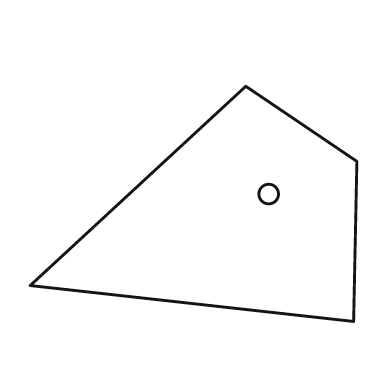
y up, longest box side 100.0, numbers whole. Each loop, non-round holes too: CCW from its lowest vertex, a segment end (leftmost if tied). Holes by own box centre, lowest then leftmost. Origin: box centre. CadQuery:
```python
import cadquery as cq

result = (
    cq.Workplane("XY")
    .moveTo(49.0, -36.0)
    .lineTo(50.0, 13.0)
    .lineTo(16.0, 36.0)
    .lineTo(-50.0, -25.0)
    .close()
    .moveTo(23.0, 3.0)
    .circle(3.0)
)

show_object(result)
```